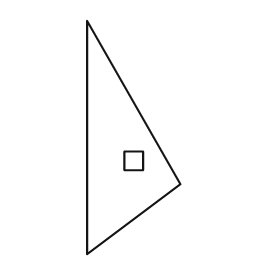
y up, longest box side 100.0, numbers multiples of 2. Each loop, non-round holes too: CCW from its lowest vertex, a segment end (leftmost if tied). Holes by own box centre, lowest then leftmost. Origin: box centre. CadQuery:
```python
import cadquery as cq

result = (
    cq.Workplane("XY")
    .moveTo(-20.0, -50.0)
    .lineTo(20.0, -20.0)
    .lineTo(-20.0, 50.0)
    .close()
    .moveTo(-4.0, -14.0)
    .lineTo(4.0, -14.0)
    .lineTo(4.0, -6.0)
    .lineTo(-4.0, -6.0)
    .close()
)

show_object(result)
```